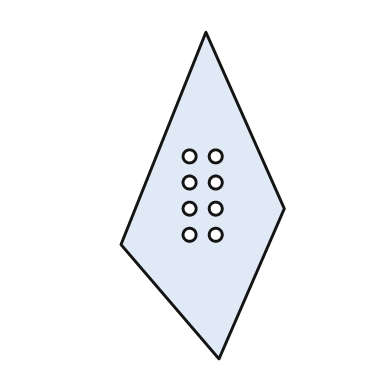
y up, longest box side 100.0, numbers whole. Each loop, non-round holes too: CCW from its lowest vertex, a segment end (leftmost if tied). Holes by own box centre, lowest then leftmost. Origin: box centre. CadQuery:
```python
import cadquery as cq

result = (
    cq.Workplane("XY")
    .moveTo(5.0, -50.0)
    .lineTo(25.0, -4.0)
    .lineTo(1.0, 50.0)
    .lineTo(-25.0, -15.0)
    .close()
    .moveTo(-4.0, -12.0)
    .circle(2.0)
    .moveTo(4.0, -12.0)
    .circle(2.0)
    .moveTo(-4.0, -4.0)
    .circle(2.0)
    .moveTo(4.0, -4.0)
    .circle(2.0)
    .moveTo(-4.0, 4.0)
    .circle(2.0)
    .moveTo(4.0, 4.0)
    .circle(2.0)
    .moveTo(-4.0, 12.0)
    .circle(2.0)
    .moveTo(4.0, 12.0)
    .circle(2.0)
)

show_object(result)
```